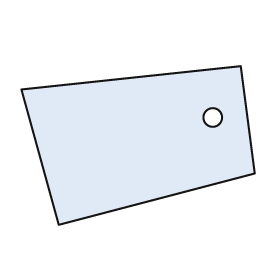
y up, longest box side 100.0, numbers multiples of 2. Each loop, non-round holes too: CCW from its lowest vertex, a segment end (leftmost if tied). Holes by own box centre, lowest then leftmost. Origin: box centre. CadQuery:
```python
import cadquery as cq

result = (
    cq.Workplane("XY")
    .moveTo(-34.0, -34.0)
    .lineTo(50.0, -12.0)
    .lineTo(44.0, 34.0)
    .lineTo(-50.0, 24.0)
    .close()
    .moveTo(32.0, 12.0)
    .circle(4.0)
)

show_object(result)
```